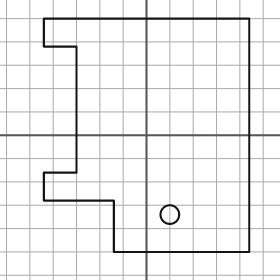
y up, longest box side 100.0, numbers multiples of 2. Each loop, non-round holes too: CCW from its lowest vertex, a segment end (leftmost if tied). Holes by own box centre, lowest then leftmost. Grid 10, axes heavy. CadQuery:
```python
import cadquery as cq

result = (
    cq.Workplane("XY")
    .moveTo(-14.0, -50.0)
    .lineTo(44.0, -50.0)
    .lineTo(44.0, 50.0)
    .lineTo(-44.0, 50.0)
    .lineTo(-44.0, 38.0)
    .lineTo(-30.0, 38.0)
    .lineTo(-30.0, -16.0)
    .lineTo(-44.0, -16.0)
    .lineTo(-44.0, -28.0)
    .lineTo(-14.0, -28.0)
    .close()
    .moveTo(10.0, -34.0)
    .circle(4.0)
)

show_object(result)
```